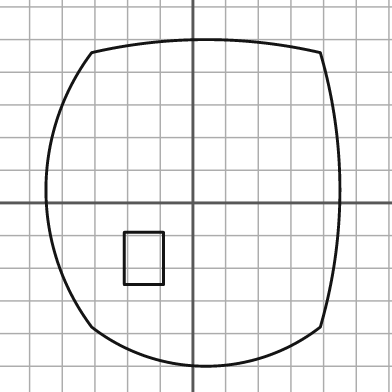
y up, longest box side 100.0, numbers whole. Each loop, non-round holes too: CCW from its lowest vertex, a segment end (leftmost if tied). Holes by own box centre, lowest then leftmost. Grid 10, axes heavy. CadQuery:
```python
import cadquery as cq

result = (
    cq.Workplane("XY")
    .moveTo(-31.0, -38.0)
    .threePointArc((4.0, -50.0), (39.0, -38.0))
    .threePointArc((45.0, 4.0), (39.0, 46.0))
    .threePointArc((4.0, 50.0), (-31.0, 46.0))
    .threePointArc((-45.0, 4.0), (-31.0, -38.0))
    .close()
    .moveTo(-21.0, -25.0)
    .lineTo(-9.0, -25.0)
    .lineTo(-9.0, -9.0)
    .lineTo(-21.0, -9.0)
    .close()
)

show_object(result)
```